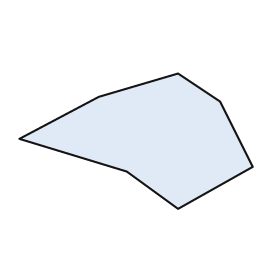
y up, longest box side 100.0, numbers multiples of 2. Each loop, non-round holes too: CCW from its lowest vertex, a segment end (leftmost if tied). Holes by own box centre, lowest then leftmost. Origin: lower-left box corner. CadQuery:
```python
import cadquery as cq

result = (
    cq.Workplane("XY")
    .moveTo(68.0, 0.0)
    .lineTo(100.0, 18.0)
    .lineTo(86.0, 46.0)
    .lineTo(68.0, 58.0)
    .lineTo(34.0, 48.0)
    .lineTo(0.0, 30.0)
    .lineTo(46.0, 16.0)
    .close()
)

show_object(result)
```